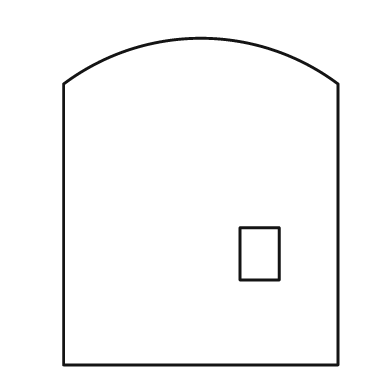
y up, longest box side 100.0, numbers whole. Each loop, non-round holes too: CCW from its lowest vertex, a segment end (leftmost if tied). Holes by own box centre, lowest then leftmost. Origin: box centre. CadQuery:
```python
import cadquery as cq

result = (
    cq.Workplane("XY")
    .moveTo(-42.0, -50.0)
    .lineTo(42.0, -50.0)
    .lineTo(42.0, 36.0)
    .threePointArc((0.0, 50.0), (-42.0, 36.0))
    .close()
    .moveTo(12.0, -24.0)
    .lineTo(24.0, -24.0)
    .lineTo(24.0, -8.0)
    .lineTo(12.0, -8.0)
    .close()
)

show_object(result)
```